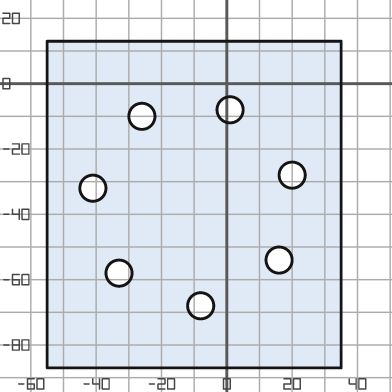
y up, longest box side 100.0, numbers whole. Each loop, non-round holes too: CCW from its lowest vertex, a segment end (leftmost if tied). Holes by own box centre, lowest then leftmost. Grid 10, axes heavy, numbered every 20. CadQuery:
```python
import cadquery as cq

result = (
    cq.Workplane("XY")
    .moveTo(-55.0, -87.0)
    .lineTo(35.0, -87.0)
    .lineTo(35.0, 13.0)
    .lineTo(-55.0, 13.0)
    .close()
    .moveTo(-8.0, -68.0)
    .circle(4.0)
    .moveTo(-33.0, -58.0)
    .circle(4.0)
    .moveTo(16.0, -54.0)
    .circle(4.0)
    .moveTo(-41.0, -32.0)
    .circle(4.0)
    .moveTo(20.0, -28.0)
    .circle(4.0)
    .moveTo(-26.0, -10.0)
    .circle(4.0)
    .moveTo(1.0, -8.0)
    .circle(4.0)
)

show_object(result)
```